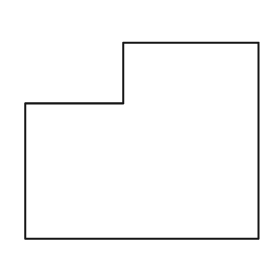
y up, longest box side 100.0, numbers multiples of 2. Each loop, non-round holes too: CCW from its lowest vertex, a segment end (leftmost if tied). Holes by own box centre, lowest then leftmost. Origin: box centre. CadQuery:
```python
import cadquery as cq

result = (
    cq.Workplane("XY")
    .moveTo(-50.0, -42.0)
    .lineTo(50.0, -42.0)
    .lineTo(50.0, 42.0)
    .lineTo(-8.0, 42.0)
    .lineTo(-8.0, 16.0)
    .lineTo(-50.0, 16.0)
    .close()
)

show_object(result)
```